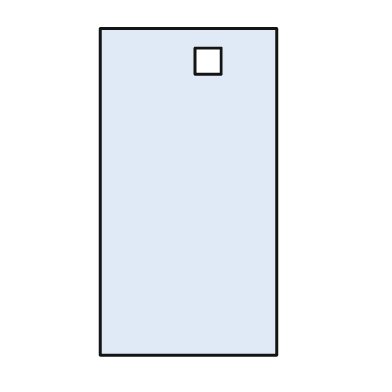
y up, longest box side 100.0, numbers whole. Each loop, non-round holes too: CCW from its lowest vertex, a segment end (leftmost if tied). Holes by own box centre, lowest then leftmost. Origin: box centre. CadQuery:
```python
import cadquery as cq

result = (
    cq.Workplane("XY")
    .moveTo(-27.0, -50.0)
    .lineTo(27.0, -50.0)
    .lineTo(27.0, 50.0)
    .lineTo(-27.0, 50.0)
    .close()
    .moveTo(2.0, 36.0)
    .lineTo(10.0, 36.0)
    .lineTo(10.0, 44.0)
    .lineTo(2.0, 44.0)
    .close()
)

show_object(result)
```